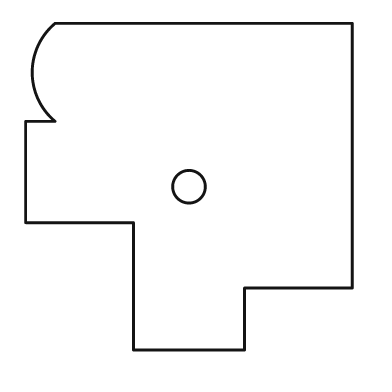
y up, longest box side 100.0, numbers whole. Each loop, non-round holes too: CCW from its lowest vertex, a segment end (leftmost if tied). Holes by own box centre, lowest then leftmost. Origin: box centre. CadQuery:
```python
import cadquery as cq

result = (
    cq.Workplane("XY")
    .moveTo(-17.0, -50.0)
    .lineTo(17.0, -50.0)
    .lineTo(17.0, -31.0)
    .lineTo(50.0, -31.0)
    .lineTo(50.0, 50.0)
    .lineTo(-41.0, 50.0)
    .threePointArc((-48.0, 35.0), (-41.0, 20.0))
    .lineTo(-50.0, 20.0)
    .lineTo(-50.0, -11.0)
    .lineTo(-17.0, -11.0)
    .close()
    .moveTo(0.0, 0.0)
    .circle(5.0)
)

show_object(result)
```